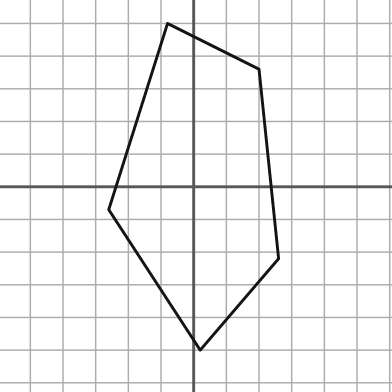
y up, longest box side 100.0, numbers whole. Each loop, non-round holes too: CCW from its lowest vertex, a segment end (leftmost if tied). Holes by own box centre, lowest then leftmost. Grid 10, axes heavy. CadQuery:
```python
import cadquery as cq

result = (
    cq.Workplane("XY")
    .moveTo(2.0, -50.0)
    .lineTo(26.0, -22.0)
    .lineTo(20.0, 36.0)
    .lineTo(-8.0, 50.0)
    .lineTo(-26.0, -7.0)
    .close()
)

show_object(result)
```